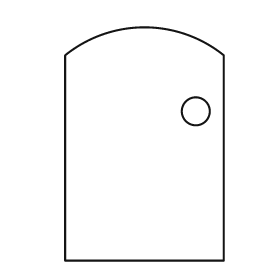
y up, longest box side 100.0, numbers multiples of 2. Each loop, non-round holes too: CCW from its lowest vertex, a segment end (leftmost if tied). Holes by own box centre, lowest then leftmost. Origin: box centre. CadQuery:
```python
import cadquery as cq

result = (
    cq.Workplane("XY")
    .moveTo(-34.0, -50.0)
    .lineTo(34.0, -50.0)
    .lineTo(34.0, 38.0)
    .threePointArc((0.0, 50.0), (-34.0, 38.0))
    .close()
    .moveTo(22.0, 14.0)
    .circle(6.0)
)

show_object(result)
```